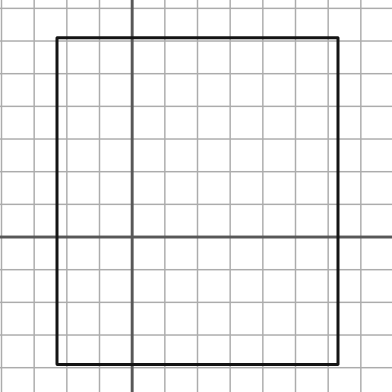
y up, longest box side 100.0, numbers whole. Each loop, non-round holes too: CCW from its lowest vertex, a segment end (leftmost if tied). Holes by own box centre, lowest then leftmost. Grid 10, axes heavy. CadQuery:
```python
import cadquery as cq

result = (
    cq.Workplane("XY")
    .moveTo(-23.0, -39.0)
    .lineTo(63.0, -39.0)
    .lineTo(63.0, 61.0)
    .lineTo(-23.0, 61.0)
    .close()
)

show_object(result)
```